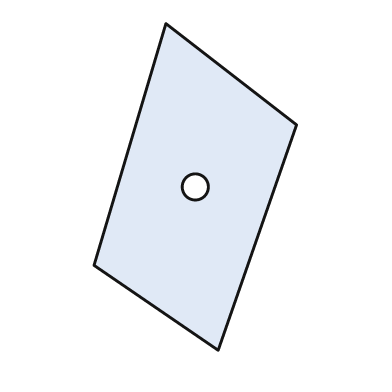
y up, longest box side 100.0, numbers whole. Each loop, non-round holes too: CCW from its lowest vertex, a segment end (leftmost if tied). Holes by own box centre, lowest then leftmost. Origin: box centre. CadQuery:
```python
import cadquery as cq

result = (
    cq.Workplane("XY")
    .moveTo(7.0, -50.0)
    .lineTo(31.0, 19.0)
    .lineTo(-9.0, 50.0)
    .lineTo(-31.0, -24.0)
    .close()
    .moveTo(0.0, 0.0)
    .circle(4.0)
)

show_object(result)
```